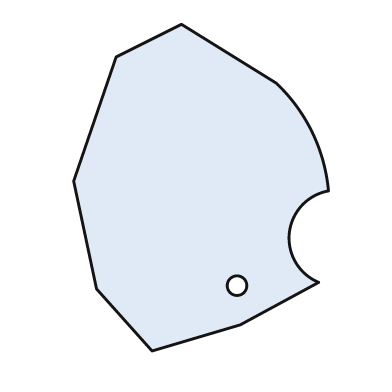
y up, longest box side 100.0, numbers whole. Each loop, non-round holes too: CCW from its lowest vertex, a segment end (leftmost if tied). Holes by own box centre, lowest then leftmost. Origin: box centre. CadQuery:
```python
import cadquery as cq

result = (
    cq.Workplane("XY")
    .moveTo(-15.0, -50.0)
    .lineTo(12.0, -42.0)
    .lineTo(36.0, -29.0)
    .threePointArc((27.0, -14.0), (39.0, -1.0))
    .threePointArc((34.0, 17.0), (23.0, 32.0))
    .lineTo(-6.0, 50.0)
    .lineTo(-26.0, 40.0)
    .lineTo(-39.0, 2.0)
    .lineTo(-32.0, -31.0)
    .close()
    .moveTo(11.0, -30.0)
    .circle(3.0)
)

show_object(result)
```